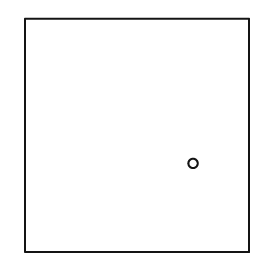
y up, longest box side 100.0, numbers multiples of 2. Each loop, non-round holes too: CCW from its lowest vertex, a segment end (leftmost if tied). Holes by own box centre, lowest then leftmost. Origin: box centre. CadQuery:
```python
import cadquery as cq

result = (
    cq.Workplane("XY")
    .moveTo(-48.0, -50.0)
    .lineTo(48.0, -50.0)
    .lineTo(48.0, 50.0)
    .lineTo(-48.0, 50.0)
    .close()
    .moveTo(24.0, -12.0)
    .circle(2.0)
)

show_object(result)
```